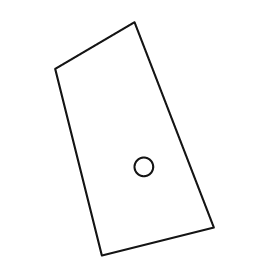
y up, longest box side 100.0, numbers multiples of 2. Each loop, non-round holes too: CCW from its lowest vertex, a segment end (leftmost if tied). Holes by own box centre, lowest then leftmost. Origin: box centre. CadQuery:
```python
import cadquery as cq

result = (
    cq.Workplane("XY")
    .moveTo(-14.0, -50.0)
    .lineTo(34.0, -38.0)
    .lineTo(0.0, 50.0)
    .lineTo(-34.0, 30.0)
    .close()
    .moveTo(4.0, -12.0)
    .circle(4.0)
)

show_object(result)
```